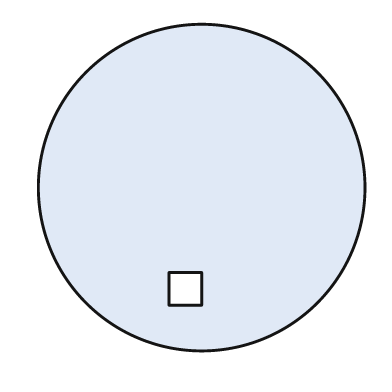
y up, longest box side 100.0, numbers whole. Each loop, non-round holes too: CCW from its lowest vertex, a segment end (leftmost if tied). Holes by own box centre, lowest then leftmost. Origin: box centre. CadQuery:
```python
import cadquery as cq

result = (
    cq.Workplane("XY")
    .moveTo(0.0, 0.0)
    .circle(50.0)
    .moveTo(-10.0, -36.0)
    .lineTo(0.0, -36.0)
    .lineTo(0.0, -26.0)
    .lineTo(-10.0, -26.0)
    .close()
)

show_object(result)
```